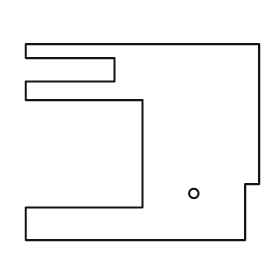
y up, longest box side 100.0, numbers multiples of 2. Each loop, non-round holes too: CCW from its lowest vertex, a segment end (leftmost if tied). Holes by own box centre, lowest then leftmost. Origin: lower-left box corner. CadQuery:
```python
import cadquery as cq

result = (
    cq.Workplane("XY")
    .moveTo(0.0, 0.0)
    .lineTo(94.0, 0.0)
    .lineTo(94.0, 24.0)
    .lineTo(100.0, 24.0)
    .lineTo(100.0, 84.0)
    .lineTo(0.0, 84.0)
    .lineTo(0.0, 78.0)
    .lineTo(38.0, 78.0)
    .lineTo(38.0, 68.0)
    .lineTo(0.0, 68.0)
    .lineTo(0.0, 60.0)
    .lineTo(50.0, 60.0)
    .lineTo(50.0, 14.0)
    .lineTo(0.0, 14.0)
    .close()
    .moveTo(72.0, 20.0)
    .circle(2.0)
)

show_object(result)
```